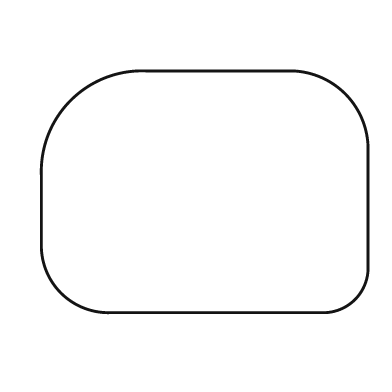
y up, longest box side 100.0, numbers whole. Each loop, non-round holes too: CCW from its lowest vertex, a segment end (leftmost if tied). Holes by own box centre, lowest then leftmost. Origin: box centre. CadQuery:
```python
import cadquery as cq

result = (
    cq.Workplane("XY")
    .moveTo(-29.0, -37.0)
    .lineTo(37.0, -37.0)
    .threePointArc((46.0, -33.0), (50.0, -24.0))
    .lineTo(50.0, 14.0)
    .threePointArc((43.0, 30.0), (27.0, 37.0))
    .lineTo(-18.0, 37.0)
    .threePointArc((-41.0, 28.0), (-50.0, 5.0))
    .lineTo(-50.0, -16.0)
    .threePointArc((-44.0, -31.0), (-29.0, -37.0))
    .close()
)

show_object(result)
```